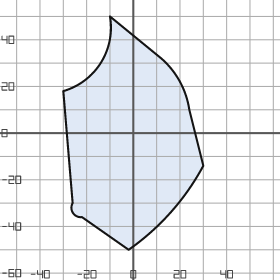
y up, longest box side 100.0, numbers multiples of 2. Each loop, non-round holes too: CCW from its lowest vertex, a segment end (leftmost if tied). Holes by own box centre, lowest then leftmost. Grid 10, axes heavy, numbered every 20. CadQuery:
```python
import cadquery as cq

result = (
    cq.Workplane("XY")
    .moveTo(-2.0, -50.0)
    .threePointArc((16.0, -34.0), (30.0, -14.0))
    .lineTo(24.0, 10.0)
    .threePointArc((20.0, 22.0), (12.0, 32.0))
    .lineTo(-10.0, 50.0)
    .threePointArc((-14.0, 30.0), (-30.0, 18.0))
    .lineTo(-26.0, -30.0)
    .threePointArc((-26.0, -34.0), (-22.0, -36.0))
    .close()
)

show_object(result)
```